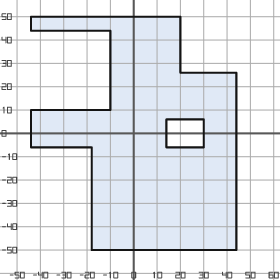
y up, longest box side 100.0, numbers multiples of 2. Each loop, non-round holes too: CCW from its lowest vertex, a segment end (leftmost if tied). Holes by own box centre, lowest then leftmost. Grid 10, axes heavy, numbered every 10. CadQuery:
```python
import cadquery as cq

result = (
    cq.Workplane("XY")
    .moveTo(-18.0, -50.0)
    .lineTo(44.0, -50.0)
    .lineTo(44.0, 26.0)
    .lineTo(20.0, 26.0)
    .lineTo(20.0, 50.0)
    .lineTo(-44.0, 50.0)
    .lineTo(-44.0, 44.0)
    .lineTo(-10.0, 44.0)
    .lineTo(-10.0, 10.0)
    .lineTo(-44.0, 10.0)
    .lineTo(-44.0, -6.0)
    .lineTo(-18.0, -6.0)
    .close()
    .moveTo(14.0, -6.0)
    .lineTo(30.0, -6.0)
    .lineTo(30.0, 6.0)
    .lineTo(14.0, 6.0)
    .close()
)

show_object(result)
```